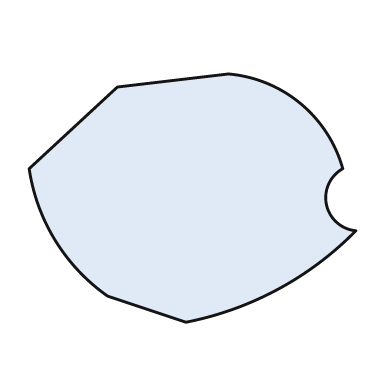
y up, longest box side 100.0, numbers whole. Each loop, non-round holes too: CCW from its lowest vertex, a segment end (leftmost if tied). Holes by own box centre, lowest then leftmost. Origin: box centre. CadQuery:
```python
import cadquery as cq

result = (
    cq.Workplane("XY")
    .moveTo(-2.0, -38.0)
    .threePointArc((26.0, -28.0), (50.0, -10.0))
    .threePointArc((41.0, -2.0), (46.0, 9.0))
    .threePointArc((33.0, 29.0), (11.0, 38.0))
    .lineTo(-23.0, 34.0)
    .lineTo(-50.0, 9.0)
    .threePointArc((-42.0, -13.0), (-26.0, -30.0))
    .close()
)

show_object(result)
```